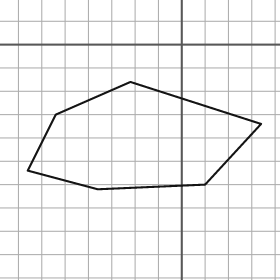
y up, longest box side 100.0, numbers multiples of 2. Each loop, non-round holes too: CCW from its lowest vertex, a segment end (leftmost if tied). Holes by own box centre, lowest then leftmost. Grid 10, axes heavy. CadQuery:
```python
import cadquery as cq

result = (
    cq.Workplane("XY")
    .moveTo(-36.0, -62.0)
    .lineTo(10.0, -60.0)
    .lineTo(34.0, -34.0)
    .lineTo(-22.0, -16.0)
    .lineTo(-54.0, -30.0)
    .lineTo(-66.0, -54.0)
    .close()
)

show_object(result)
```